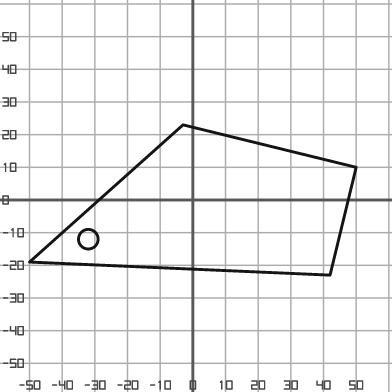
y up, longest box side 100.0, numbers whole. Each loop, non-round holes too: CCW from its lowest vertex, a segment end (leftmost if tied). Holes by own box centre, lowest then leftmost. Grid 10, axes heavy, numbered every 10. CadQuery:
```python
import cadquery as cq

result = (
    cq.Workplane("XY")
    .moveTo(42.0, -23.0)
    .lineTo(50.0, 10.0)
    .lineTo(-3.0, 23.0)
    .lineTo(-50.0, -19.0)
    .close()
    .moveTo(-32.0, -12.0)
    .circle(3.0)
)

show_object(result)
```